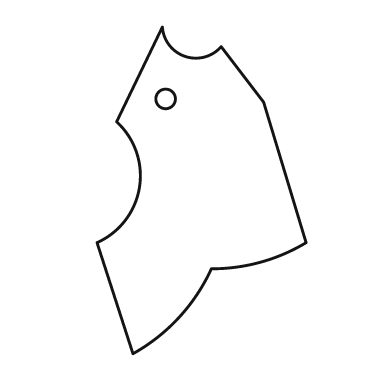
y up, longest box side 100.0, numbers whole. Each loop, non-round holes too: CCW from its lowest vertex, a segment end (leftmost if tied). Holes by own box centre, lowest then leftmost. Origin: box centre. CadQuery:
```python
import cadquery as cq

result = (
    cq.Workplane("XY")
    .moveTo(-21.0, -50.0)
    .threePointArc((-7.0, -39.0), (3.0, -24.0))
    .threePointArc((18.0, -22.0), (32.0, -16.0))
    .lineTo(19.0, 27.0)
    .lineTo(6.0, 44.0)
    .threePointArc((-5.0, 41.0), (-12.0, 50.0))
    .lineTo(-26.0, 21.0)
    .threePointArc((-19.0, 1.0), (-32.0, -16.0))
    .close()
    .moveTo(-11.0, 28.0)
    .circle(3.0)
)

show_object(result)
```